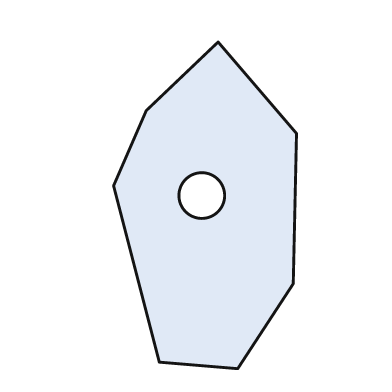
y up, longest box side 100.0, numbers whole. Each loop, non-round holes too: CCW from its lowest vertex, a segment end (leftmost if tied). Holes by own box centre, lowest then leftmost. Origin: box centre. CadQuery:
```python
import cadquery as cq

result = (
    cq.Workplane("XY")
    .moveTo(10.0, -50.0)
    .lineTo(27.0, -24.0)
    .lineTo(28.0, 22.0)
    .lineTo(4.0, 50.0)
    .lineTo(-18.0, 29.0)
    .lineTo(-28.0, 6.0)
    .lineTo(-14.0, -48.0)
    .close()
    .moveTo(-1.0, 3.0)
    .circle(7.0)
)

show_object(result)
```